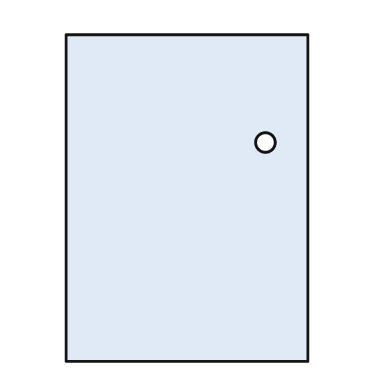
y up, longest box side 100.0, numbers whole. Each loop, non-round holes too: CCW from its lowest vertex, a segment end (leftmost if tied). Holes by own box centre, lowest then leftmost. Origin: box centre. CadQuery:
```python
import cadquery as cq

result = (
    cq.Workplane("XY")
    .moveTo(-37.0, -50.0)
    .lineTo(37.0, -50.0)
    .lineTo(37.0, 50.0)
    .lineTo(-37.0, 50.0)
    .close()
    .moveTo(24.0, 17.0)
    .circle(3.0)
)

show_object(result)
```